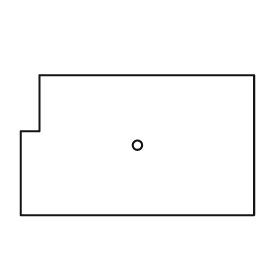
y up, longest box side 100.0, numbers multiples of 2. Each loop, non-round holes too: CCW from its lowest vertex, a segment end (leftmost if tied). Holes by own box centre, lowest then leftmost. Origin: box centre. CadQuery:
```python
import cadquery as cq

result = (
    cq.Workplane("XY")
    .moveTo(-50.0, -30.0)
    .lineTo(50.0, -30.0)
    .lineTo(50.0, 30.0)
    .lineTo(-42.0, 30.0)
    .lineTo(-42.0, 6.0)
    .lineTo(-50.0, 6.0)
    .close()
    .moveTo(0.0, 0.0)
    .circle(2.0)
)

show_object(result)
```